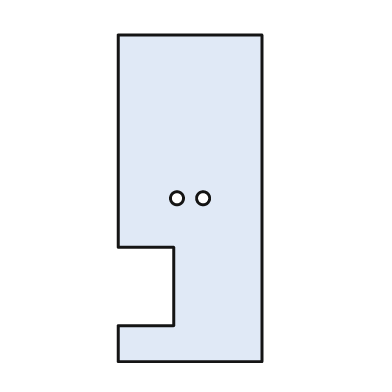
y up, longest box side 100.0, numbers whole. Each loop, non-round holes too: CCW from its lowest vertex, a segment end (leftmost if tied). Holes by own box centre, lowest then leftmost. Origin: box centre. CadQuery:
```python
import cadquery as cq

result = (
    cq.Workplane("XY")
    .moveTo(-22.0, -50.0)
    .lineTo(22.0, -50.0)
    .lineTo(22.0, 50.0)
    .lineTo(-22.0, 50.0)
    .lineTo(-22.0, -15.0)
    .lineTo(-5.0, -15.0)
    .lineTo(-5.0, -39.0)
    .lineTo(-22.0, -39.0)
    .close()
    .moveTo(-4.0, 0.0)
    .circle(2.0)
    .moveTo(4.0, 0.0)
    .circle(2.0)
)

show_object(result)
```